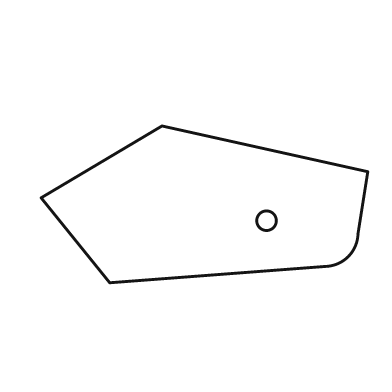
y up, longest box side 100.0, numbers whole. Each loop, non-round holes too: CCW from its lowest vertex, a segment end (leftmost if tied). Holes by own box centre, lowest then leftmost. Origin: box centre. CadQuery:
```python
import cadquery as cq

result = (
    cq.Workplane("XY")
    .moveTo(-29.0, -24.0)
    .lineTo(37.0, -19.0)
    .threePointArc((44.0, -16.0), (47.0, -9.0))
    .lineTo(50.0, 10.0)
    .lineTo(-13.0, 24.0)
    .lineTo(-50.0, 2.0)
    .close()
    .moveTo(19.0, -5.0)
    .circle(3.0)
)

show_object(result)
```